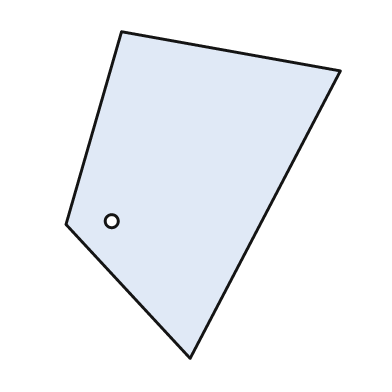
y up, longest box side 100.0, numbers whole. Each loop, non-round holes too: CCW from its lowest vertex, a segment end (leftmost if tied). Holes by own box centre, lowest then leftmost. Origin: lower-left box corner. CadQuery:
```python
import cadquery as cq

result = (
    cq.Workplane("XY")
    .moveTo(38.0, 0.0)
    .lineTo(84.0, 88.0)
    .lineTo(17.0, 100.0)
    .lineTo(0.0, 41.0)
    .close()
    .moveTo(14.0, 42.0)
    .circle(2.0)
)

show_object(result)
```